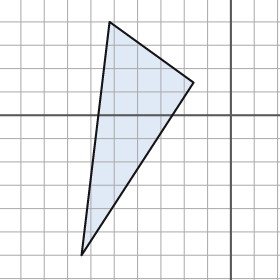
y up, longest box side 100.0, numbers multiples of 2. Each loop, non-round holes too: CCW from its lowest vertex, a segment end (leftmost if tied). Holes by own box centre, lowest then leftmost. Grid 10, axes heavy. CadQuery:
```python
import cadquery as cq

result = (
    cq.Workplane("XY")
    .moveTo(-64.0, -60.0)
    .lineTo(-16.0, 14.0)
    .lineTo(-52.0, 40.0)
    .close()
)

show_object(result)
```